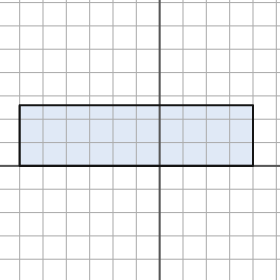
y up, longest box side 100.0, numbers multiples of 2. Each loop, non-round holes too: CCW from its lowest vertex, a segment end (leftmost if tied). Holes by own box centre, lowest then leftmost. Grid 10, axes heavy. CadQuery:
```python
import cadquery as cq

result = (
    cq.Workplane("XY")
    .moveTo(-60.0, 0.0)
    .lineTo(40.0, 0.0)
    .lineTo(40.0, 26.0)
    .lineTo(-60.0, 26.0)
    .close()
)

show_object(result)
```